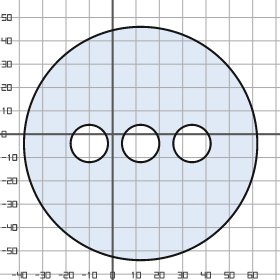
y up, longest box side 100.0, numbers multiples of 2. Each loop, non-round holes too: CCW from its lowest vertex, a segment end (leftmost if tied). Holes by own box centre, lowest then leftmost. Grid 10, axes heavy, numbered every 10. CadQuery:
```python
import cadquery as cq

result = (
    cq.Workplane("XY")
    .moveTo(12.0, -4.0)
    .circle(50.0)
    .moveTo(-10.0, -4.0)
    .circle(8.0)
    .moveTo(12.0, -4.0)
    .circle(8.0)
    .moveTo(34.0, -4.0)
    .circle(8.0)
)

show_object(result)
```